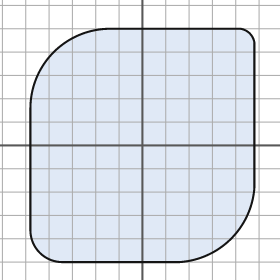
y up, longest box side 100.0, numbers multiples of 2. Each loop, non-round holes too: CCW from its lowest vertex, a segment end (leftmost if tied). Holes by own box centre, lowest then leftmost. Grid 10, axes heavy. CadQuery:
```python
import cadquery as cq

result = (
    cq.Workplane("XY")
    .moveTo(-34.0, -50.0)
    .lineTo(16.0, -50.0)
    .threePointArc((38.0, -40.0), (48.0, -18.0))
    .lineTo(48.0, 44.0)
    .threePointArc((46.0, 48.0), (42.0, 50.0))
    .lineTo(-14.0, 50.0)
    .threePointArc((-38.0, 40.0), (-48.0, 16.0))
    .lineTo(-48.0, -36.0)
    .threePointArc((-44.0, -46.0), (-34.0, -50.0))
    .close()
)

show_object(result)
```